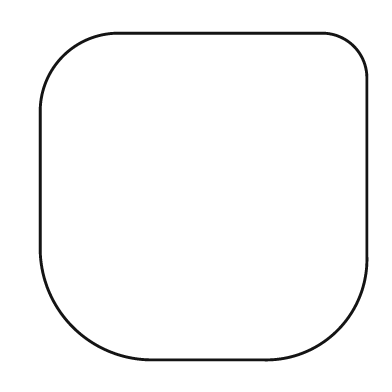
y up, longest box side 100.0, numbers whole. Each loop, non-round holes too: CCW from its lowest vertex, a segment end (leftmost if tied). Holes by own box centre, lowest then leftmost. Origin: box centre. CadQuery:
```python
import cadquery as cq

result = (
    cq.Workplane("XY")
    .moveTo(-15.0, -50.0)
    .lineTo(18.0, -50.0)
    .threePointArc((41.0, -41.0), (50.0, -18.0))
    .lineTo(50.0, 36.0)
    .threePointArc((46.0, 46.0), (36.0, 50.0))
    .lineTo(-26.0, 50.0)
    .threePointArc((-43.0, 43.0), (-50.0, 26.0))
    .lineTo(-50.0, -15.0)
    .threePointArc((-40.0, -40.0), (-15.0, -50.0))
    .close()
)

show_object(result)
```